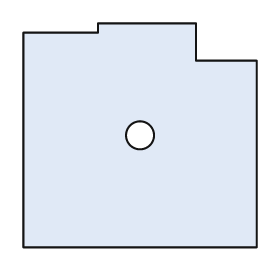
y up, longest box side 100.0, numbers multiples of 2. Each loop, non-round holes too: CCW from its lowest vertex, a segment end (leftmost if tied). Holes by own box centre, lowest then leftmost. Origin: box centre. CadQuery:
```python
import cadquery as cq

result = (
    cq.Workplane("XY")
    .moveTo(-50.0, -48.0)
    .lineTo(50.0, -48.0)
    .lineTo(50.0, 32.0)
    .lineTo(24.0, 32.0)
    .lineTo(24.0, 48.0)
    .lineTo(-18.0, 48.0)
    .lineTo(-18.0, 44.0)
    .lineTo(-50.0, 44.0)
    .close()
    .moveTo(0.0, 0.0)
    .circle(6.0)
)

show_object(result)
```